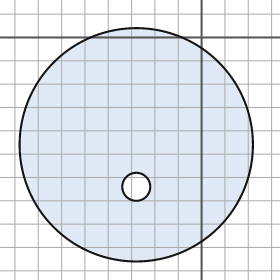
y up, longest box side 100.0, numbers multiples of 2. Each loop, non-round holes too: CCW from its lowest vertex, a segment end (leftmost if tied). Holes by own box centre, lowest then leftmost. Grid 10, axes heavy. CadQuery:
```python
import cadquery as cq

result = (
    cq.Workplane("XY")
    .moveTo(-28.0, -46.0)
    .circle(50.0)
    .moveTo(-28.0, -64.0)
    .circle(6.0)
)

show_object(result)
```